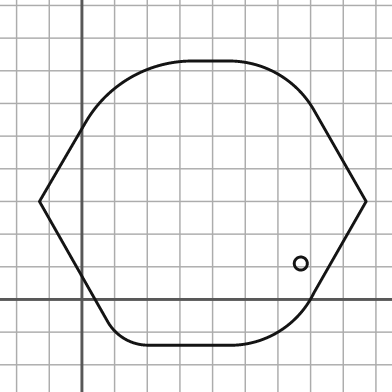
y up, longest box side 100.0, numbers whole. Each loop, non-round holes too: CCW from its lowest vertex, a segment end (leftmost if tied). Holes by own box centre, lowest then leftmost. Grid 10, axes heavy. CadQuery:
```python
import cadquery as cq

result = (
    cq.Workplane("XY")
    .moveTo(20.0, -14.0)
    .lineTo(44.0, -14.0)
    .threePointArc((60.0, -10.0), (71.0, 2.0))
    .lineTo(87.0, 30.0)
    .lineTo(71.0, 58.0)
    .threePointArc((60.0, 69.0), (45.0, 73.0))
    .lineTo(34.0, 73.0)
    .threePointArc((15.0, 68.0), (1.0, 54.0))
    .lineTo(-13.0, 30.0)
    .lineTo(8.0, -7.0)
    .threePointArc((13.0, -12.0), (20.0, -14.0))
    .close()
    .moveTo(67.0, 11.0)
    .circle(2.0)
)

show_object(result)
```